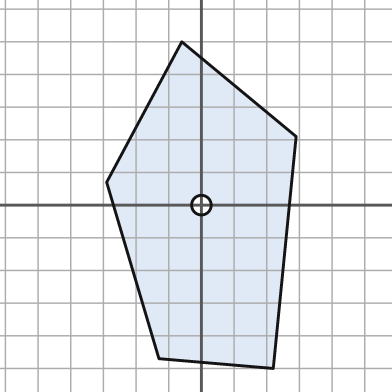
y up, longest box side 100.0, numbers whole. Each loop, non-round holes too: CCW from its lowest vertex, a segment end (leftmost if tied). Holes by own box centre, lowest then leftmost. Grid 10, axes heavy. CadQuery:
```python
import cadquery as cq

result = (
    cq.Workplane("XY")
    .moveTo(22.0, -50.0)
    .lineTo(29.0, 21.0)
    .lineTo(-6.0, 50.0)
    .lineTo(-29.0, 7.0)
    .lineTo(-13.0, -47.0)
    .close()
    .moveTo(0.0, 0.0)
    .circle(3.0)
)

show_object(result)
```